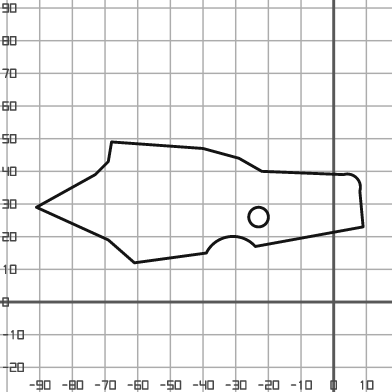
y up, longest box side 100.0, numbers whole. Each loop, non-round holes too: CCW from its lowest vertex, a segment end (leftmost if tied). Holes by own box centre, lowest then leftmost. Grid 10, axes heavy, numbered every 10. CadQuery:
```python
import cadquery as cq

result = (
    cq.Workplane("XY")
    .moveTo(-61.0, 12.0)
    .lineTo(-39.0, 15.0)
    .threePointArc((-32.0, 20.0), (-24.0, 17.0))
    .lineTo(9.0, 23.0)
    .lineTo(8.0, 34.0)
    .threePointArc((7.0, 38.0), (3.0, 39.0))
    .lineTo(-22.0, 40.0)
    .lineTo(-29.0, 44.0)
    .lineTo(-40.0, 47.0)
    .lineTo(-68.0, 49.0)
    .lineTo(-69.0, 43.0)
    .lineTo(-73.0, 39.0)
    .lineTo(-91.0, 29.0)
    .lineTo(-69.0, 19.0)
    .close()
    .moveTo(-23.0, 26.0)
    .circle(3.0)
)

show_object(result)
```